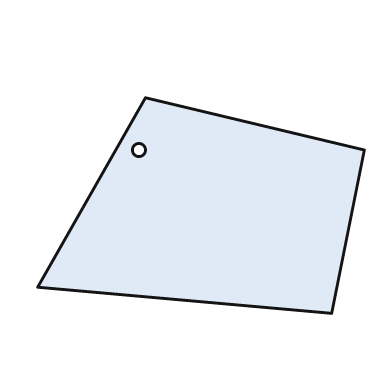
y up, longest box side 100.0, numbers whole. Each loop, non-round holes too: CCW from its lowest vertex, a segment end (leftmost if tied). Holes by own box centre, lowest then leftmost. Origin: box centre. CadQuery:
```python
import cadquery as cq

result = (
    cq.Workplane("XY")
    .moveTo(40.0, -33.0)
    .lineTo(50.0, 17.0)
    .lineTo(-17.0, 33.0)
    .lineTo(-50.0, -25.0)
    .close()
    .moveTo(-19.0, 17.0)
    .circle(2.0)
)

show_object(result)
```